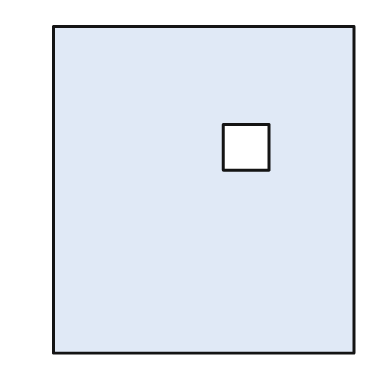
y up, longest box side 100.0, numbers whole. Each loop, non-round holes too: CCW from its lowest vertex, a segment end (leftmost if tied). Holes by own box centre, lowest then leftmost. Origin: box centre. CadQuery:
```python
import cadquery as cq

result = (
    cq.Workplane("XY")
    .moveTo(-46.0, -50.0)
    .lineTo(46.0, -50.0)
    .lineTo(46.0, 50.0)
    .lineTo(-46.0, 50.0)
    .close()
    .moveTo(6.0, 6.0)
    .lineTo(20.0, 6.0)
    .lineTo(20.0, 20.0)
    .lineTo(6.0, 20.0)
    .close()
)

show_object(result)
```